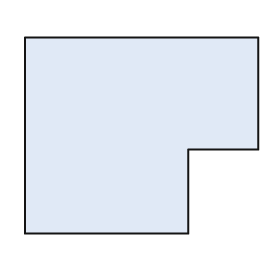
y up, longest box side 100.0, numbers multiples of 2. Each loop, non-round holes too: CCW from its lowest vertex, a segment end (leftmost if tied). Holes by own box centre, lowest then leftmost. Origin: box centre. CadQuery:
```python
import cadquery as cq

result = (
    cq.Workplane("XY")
    .moveTo(-50.0, -42.0)
    .lineTo(20.0, -42.0)
    .lineTo(20.0, -6.0)
    .lineTo(50.0, -6.0)
    .lineTo(50.0, 42.0)
    .lineTo(-50.0, 42.0)
    .close()
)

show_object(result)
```